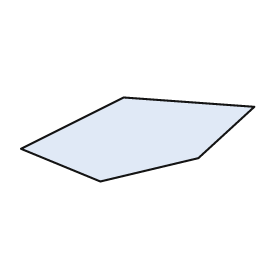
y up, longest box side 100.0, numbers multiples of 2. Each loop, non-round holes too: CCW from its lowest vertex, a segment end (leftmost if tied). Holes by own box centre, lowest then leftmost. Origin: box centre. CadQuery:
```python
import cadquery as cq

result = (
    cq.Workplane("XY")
    .moveTo(-16.0, -18.0)
    .lineTo(26.0, -8.0)
    .lineTo(50.0, 14.0)
    .lineTo(-6.0, 18.0)
    .lineTo(-50.0, -4.0)
    .close()
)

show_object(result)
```